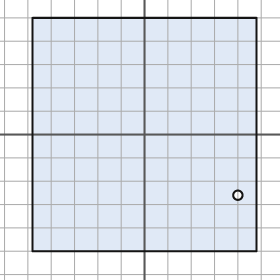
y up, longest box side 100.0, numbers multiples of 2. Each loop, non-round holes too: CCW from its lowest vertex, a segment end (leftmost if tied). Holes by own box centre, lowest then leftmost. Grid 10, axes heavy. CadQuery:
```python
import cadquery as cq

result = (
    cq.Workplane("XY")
    .moveTo(-48.0, -50.0)
    .lineTo(48.0, -50.0)
    .lineTo(48.0, 50.0)
    .lineTo(-48.0, 50.0)
    .close()
    .moveTo(40.0, -26.0)
    .circle(2.0)
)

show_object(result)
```